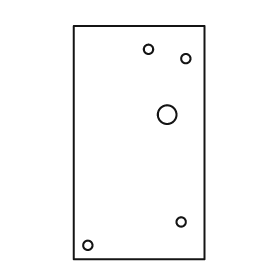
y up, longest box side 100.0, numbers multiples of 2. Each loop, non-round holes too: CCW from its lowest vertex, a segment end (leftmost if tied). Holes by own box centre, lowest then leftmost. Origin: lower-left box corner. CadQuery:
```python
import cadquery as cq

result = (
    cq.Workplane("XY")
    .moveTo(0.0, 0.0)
    .lineTo(56.0, 0.0)
    .lineTo(56.0, 100.0)
    .lineTo(0.0, 100.0)
    .close()
    .moveTo(6.0, 6.0)
    .circle(2.0)
    .moveTo(46.0, 16.0)
    .circle(2.0)
    .moveTo(40.0, 62.0)
    .circle(4.0)
    .moveTo(48.0, 86.0)
    .circle(2.0)
    .moveTo(32.0, 90.0)
    .circle(2.0)
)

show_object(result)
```